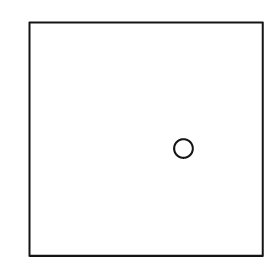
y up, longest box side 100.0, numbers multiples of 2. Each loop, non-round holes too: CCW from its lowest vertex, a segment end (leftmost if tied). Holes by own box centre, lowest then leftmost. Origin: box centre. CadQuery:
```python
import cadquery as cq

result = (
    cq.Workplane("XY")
    .moveTo(-50.0, -50.0)
    .lineTo(50.0, -50.0)
    .lineTo(50.0, 50.0)
    .lineTo(-50.0, 50.0)
    .close()
    .moveTo(16.0, -4.0)
    .circle(4.0)
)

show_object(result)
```